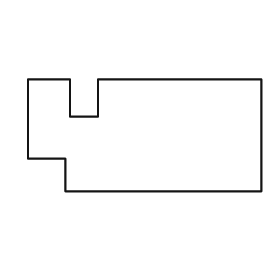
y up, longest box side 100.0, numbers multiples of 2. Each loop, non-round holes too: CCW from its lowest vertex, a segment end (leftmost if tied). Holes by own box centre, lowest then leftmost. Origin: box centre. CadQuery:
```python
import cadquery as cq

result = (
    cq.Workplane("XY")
    .moveTo(-34.0, -24.0)
    .lineTo(50.0, -24.0)
    .lineTo(50.0, 24.0)
    .lineTo(-20.0, 24.0)
    .lineTo(-20.0, 8.0)
    .lineTo(-32.0, 8.0)
    .lineTo(-32.0, 24.0)
    .lineTo(-50.0, 24.0)
    .lineTo(-50.0, -10.0)
    .lineTo(-34.0, -10.0)
    .close()
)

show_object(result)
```